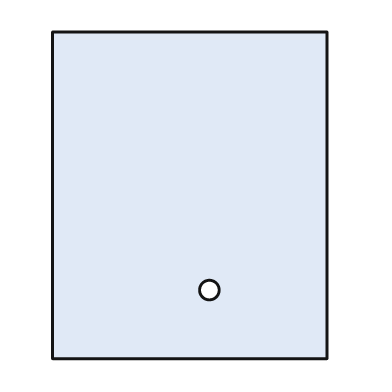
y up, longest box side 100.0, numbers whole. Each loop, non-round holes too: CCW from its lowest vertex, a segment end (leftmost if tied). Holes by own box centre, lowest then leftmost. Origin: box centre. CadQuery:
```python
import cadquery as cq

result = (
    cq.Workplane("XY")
    .moveTo(-42.0, -50.0)
    .lineTo(42.0, -50.0)
    .lineTo(42.0, 50.0)
    .lineTo(-42.0, 50.0)
    .close()
    .moveTo(6.0, -29.0)
    .circle(3.0)
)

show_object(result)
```